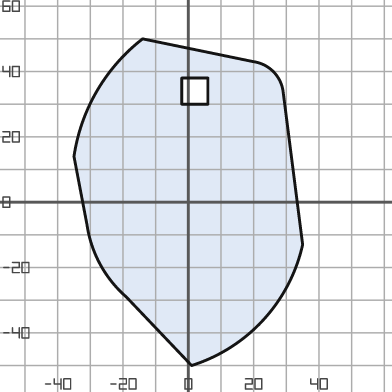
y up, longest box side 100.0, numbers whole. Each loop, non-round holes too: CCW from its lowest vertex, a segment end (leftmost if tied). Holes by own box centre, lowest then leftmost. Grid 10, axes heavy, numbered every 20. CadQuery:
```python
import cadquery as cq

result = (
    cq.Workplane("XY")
    .moveTo(1.0, -50.0)
    .threePointArc((23.0, -36.0), (35.0, -13.0))
    .lineTo(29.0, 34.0)
    .threePointArc((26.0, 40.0), (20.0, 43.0))
    .lineTo(-14.0, 50.0)
    .threePointArc((-28.0, 34.0), (-35.0, 14.0))
    .lineTo(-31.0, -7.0)
    .threePointArc((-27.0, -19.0), (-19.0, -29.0))
    .close()
    .moveTo(-2.0, 30.0)
    .lineTo(6.0, 30.0)
    .lineTo(6.0, 38.0)
    .lineTo(-2.0, 38.0)
    .close()
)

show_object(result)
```